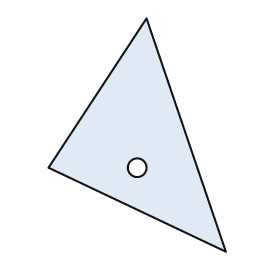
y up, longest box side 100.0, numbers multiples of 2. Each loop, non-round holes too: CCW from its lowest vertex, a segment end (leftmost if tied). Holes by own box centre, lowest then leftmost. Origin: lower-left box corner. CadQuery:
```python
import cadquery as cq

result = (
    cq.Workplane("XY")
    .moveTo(76.0, 0.0)
    .lineTo(42.0, 100.0)
    .lineTo(0.0, 36.0)
    .close()
    .moveTo(38.0, 36.0)
    .circle(4.0)
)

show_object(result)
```